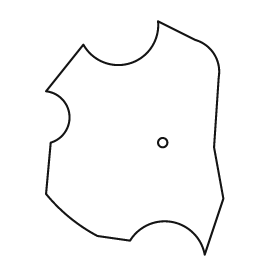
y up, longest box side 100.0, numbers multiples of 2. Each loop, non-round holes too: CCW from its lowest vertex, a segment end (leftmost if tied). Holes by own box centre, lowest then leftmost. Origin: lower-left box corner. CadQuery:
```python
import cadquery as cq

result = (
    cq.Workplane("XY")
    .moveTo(68.0, 0.0)
    .lineTo(76.0, 24.0)
    .lineTo(72.0, 46.0)
    .lineTo(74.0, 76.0)
    .threePointArc((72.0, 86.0), (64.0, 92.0))
    .lineTo(48.0, 100.0)
    .threePointArc((36.0, 82.0), (16.0, 90.0))
    .lineTo(0.0, 70.0)
    .threePointArc((10.0, 60.0), (2.0, 48.0))
    .lineTo(0.0, 26.0)
    .threePointArc((10.0, 16.0), (22.0, 8.0))
    .lineTo(36.0, 6.0)
    .threePointArc((54.0, 14.0), (68.0, 0.0))
    .close()
    .moveTo(50.0, 48.0)
    .circle(2.0)
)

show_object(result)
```